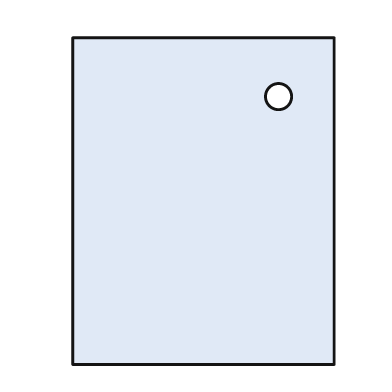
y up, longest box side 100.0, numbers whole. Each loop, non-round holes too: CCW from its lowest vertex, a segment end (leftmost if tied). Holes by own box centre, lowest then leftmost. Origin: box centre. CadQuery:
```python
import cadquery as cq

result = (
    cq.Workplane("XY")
    .moveTo(-40.0, -50.0)
    .lineTo(40.0, -50.0)
    .lineTo(40.0, 50.0)
    .lineTo(-40.0, 50.0)
    .close()
    .moveTo(23.0, 32.0)
    .circle(4.0)
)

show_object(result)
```